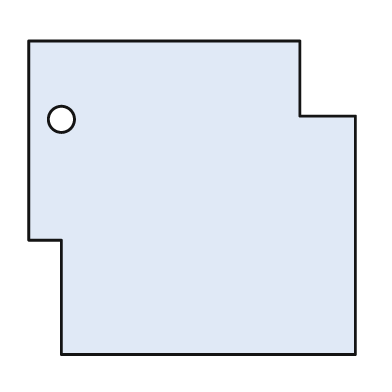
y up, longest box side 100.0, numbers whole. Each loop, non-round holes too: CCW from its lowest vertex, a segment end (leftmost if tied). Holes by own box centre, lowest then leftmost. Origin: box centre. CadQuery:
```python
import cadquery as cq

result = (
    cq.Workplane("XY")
    .moveTo(-40.0, -48.0)
    .lineTo(50.0, -48.0)
    .lineTo(50.0, 25.0)
    .lineTo(33.0, 25.0)
    .lineTo(33.0, 48.0)
    .lineTo(-50.0, 48.0)
    .lineTo(-50.0, -13.0)
    .lineTo(-40.0, -13.0)
    .close()
    .moveTo(-40.0, 24.0)
    .circle(4.0)
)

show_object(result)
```